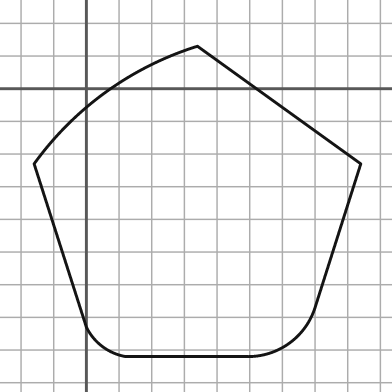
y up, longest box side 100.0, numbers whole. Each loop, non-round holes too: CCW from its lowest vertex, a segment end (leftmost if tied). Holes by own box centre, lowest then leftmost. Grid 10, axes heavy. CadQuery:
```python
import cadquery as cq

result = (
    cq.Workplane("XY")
    .moveTo(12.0, -82.0)
    .lineTo(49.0, -82.0)
    .threePointArc((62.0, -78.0), (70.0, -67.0))
    .lineTo(84.0, -23.0)
    .lineTo(34.0, 13.0)
    .threePointArc((6.0, -1.0), (-16.0, -23.0))
    .lineTo(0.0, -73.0)
    .threePointArc((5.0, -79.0), (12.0, -82.0))
    .close()
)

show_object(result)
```